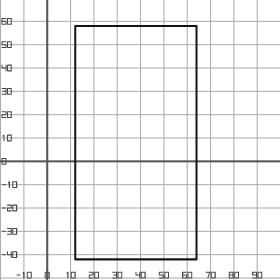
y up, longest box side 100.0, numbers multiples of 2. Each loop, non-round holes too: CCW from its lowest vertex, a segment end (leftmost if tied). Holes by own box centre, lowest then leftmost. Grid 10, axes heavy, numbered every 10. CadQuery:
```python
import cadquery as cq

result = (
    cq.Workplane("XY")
    .moveTo(12.0, -42.0)
    .lineTo(64.0, -42.0)
    .lineTo(64.0, 58.0)
    .lineTo(12.0, 58.0)
    .close()
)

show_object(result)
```